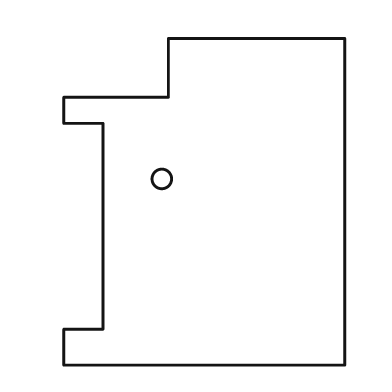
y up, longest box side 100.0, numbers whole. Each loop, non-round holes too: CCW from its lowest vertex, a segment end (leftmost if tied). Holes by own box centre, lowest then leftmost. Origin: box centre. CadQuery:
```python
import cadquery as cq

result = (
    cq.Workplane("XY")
    .moveTo(-43.0, -50.0)
    .lineTo(43.0, -50.0)
    .lineTo(43.0, 50.0)
    .lineTo(-11.0, 50.0)
    .lineTo(-11.0, 32.0)
    .lineTo(-43.0, 32.0)
    .lineTo(-43.0, 24.0)
    .lineTo(-31.0, 24.0)
    .lineTo(-31.0, -39.0)
    .lineTo(-43.0, -39.0)
    .close()
    .moveTo(-13.0, 7.0)
    .circle(3.0)
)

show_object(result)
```